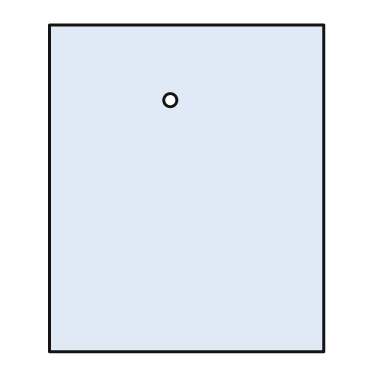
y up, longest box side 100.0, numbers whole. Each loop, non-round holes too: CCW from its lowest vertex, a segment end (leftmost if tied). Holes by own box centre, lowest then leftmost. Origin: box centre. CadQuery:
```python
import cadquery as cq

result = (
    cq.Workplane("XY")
    .moveTo(-42.0, -50.0)
    .lineTo(42.0, -50.0)
    .lineTo(42.0, 50.0)
    .lineTo(-42.0, 50.0)
    .close()
    .moveTo(-5.0, 27.0)
    .circle(2.0)
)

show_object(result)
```